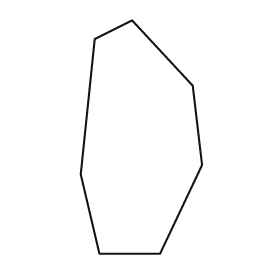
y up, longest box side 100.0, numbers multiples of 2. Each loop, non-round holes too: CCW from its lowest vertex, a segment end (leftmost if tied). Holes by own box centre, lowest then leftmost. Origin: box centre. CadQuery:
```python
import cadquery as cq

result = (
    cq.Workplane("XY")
    .moveTo(-18.0, -50.0)
    .lineTo(8.0, -50.0)
    .lineTo(26.0, -12.0)
    .lineTo(22.0, 22.0)
    .lineTo(-4.0, 50.0)
    .lineTo(-20.0, 42.0)
    .lineTo(-26.0, -16.0)
    .close()
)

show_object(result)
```